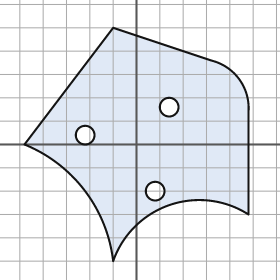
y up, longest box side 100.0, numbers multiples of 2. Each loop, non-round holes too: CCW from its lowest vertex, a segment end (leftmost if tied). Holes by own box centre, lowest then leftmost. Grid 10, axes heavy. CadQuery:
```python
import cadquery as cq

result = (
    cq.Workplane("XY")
    .moveTo(-10.0, -50.0)
    .threePointArc((14.0, -26.0), (48.0, -30.0))
    .lineTo(48.0, 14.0)
    .threePointArc((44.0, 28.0), (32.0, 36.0))
    .lineTo(-10.0, 50.0)
    .lineTo(-48.0, 0.0)
    .threePointArc((-22.0, -20.0), (-10.0, -50.0))
    .close()
    .moveTo(8.0, -20.0)
    .circle(4.0)
    .moveTo(-22.0, 4.0)
    .circle(4.0)
    .moveTo(14.0, 16.0)
    .circle(4.0)
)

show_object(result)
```